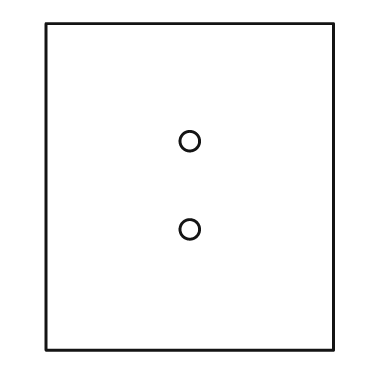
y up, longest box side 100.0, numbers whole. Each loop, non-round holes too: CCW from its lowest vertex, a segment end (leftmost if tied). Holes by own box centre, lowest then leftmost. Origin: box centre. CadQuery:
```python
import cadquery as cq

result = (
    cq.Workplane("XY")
    .moveTo(-44.0, -50.0)
    .lineTo(44.0, -50.0)
    .lineTo(44.0, 50.0)
    .lineTo(-44.0, 50.0)
    .close()
    .moveTo(0.0, -13.0)
    .circle(3.0)
    .moveTo(0.0, 14.0)
    .circle(3.0)
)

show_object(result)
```